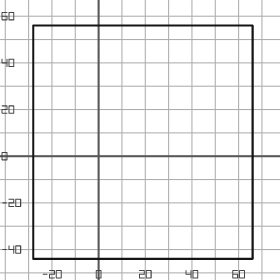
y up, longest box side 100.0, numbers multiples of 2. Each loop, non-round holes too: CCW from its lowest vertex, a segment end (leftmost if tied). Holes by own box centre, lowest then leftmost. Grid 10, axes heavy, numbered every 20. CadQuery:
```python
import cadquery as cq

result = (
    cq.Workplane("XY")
    .moveTo(-28.0, -44.0)
    .lineTo(66.0, -44.0)
    .lineTo(66.0, 56.0)
    .lineTo(-28.0, 56.0)
    .close()
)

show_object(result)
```